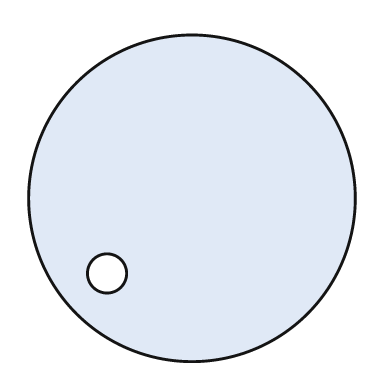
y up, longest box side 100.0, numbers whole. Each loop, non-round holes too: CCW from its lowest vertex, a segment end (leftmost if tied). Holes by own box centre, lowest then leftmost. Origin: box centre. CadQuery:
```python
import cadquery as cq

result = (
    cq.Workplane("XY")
    .moveTo(0.0, 0.0)
    .circle(50.0)
    .moveTo(-26.0, -23.0)
    .circle(6.0)
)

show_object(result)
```